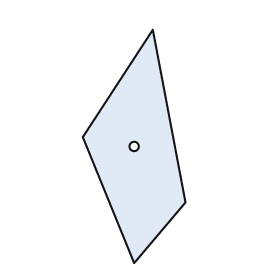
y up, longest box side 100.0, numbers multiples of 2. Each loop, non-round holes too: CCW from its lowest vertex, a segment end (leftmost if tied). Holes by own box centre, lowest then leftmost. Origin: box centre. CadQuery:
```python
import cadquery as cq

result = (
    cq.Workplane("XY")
    .moveTo(0.0, -50.0)
    .lineTo(22.0, -24.0)
    .lineTo(8.0, 50.0)
    .lineTo(-22.0, 4.0)
    .close()
    .moveTo(0.0, 0.0)
    .circle(2.0)
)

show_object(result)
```